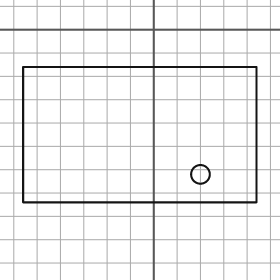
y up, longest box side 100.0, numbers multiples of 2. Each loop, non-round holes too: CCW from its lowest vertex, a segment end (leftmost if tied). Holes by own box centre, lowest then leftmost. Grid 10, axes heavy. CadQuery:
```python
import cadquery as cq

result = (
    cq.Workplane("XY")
    .moveTo(-56.0, -74.0)
    .lineTo(44.0, -74.0)
    .lineTo(44.0, -16.0)
    .lineTo(-56.0, -16.0)
    .close()
    .moveTo(20.0, -62.0)
    .circle(4.0)
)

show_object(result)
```